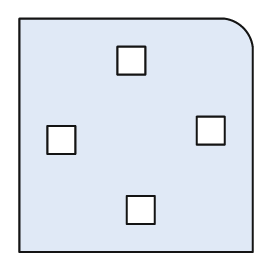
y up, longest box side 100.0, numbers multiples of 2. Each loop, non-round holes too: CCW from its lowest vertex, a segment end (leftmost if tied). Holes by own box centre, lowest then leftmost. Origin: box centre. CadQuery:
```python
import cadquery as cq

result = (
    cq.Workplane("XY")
    .moveTo(-50.0, -50.0)
    .lineTo(50.0, -50.0)
    .lineTo(50.0, 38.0)
    .threePointArc((46.0, 46.0), (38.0, 50.0))
    .lineTo(-50.0, 50.0)
    .close()
    .moveTo(-4.0, -38.0)
    .lineTo(8.0, -38.0)
    .lineTo(8.0, -26.0)
    .lineTo(-4.0, -26.0)
    .close()
    .moveTo(-38.0, -8.0)
    .lineTo(-26.0, -8.0)
    .lineTo(-26.0, 4.0)
    .lineTo(-38.0, 4.0)
    .close()
    .moveTo(26.0, -4.0)
    .lineTo(38.0, -4.0)
    .lineTo(38.0, 8.0)
    .lineTo(26.0, 8.0)
    .close()
    .moveTo(-8.0, 26.0)
    .lineTo(4.0, 26.0)
    .lineTo(4.0, 38.0)
    .lineTo(-8.0, 38.0)
    .close()
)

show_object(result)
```